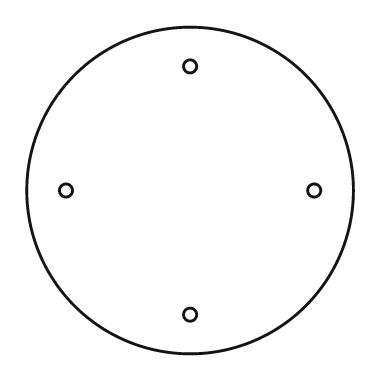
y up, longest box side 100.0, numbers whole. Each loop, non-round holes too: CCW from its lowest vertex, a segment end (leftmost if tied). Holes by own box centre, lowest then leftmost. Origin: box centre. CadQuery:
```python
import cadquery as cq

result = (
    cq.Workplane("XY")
    .moveTo(0.0, 0.0)
    .circle(50.0)
    .moveTo(0.0, -38.0)
    .circle(2.0)
    .moveTo(-38.0, 0.0)
    .circle(2.0)
    .moveTo(38.0, 0.0)
    .circle(2.0)
    .moveTo(0.0, 38.0)
    .circle(2.0)
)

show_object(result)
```